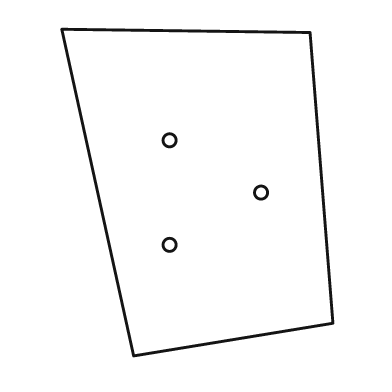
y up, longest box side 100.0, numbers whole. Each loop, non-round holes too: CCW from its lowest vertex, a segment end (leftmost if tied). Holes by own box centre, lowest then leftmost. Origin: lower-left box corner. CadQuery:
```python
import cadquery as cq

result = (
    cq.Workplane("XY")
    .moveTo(22.0, 0.0)
    .lineTo(83.0, 10.0)
    .lineTo(76.0, 99.0)
    .lineTo(0.0, 100.0)
    .close()
    .moveTo(33.0, 34.0)
    .circle(2.0)
    .moveTo(61.0, 50.0)
    .circle(2.0)
    .moveTo(33.0, 66.0)
    .circle(2.0)
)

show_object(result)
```